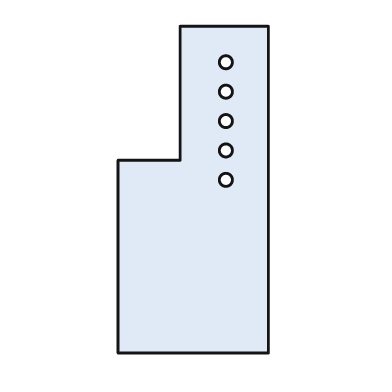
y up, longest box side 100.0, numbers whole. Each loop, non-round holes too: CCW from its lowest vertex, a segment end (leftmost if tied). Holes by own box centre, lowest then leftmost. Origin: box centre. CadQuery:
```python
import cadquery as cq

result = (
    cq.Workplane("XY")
    .moveTo(-23.0, -50.0)
    .lineTo(23.0, -50.0)
    .lineTo(23.0, 50.0)
    .lineTo(-4.0, 50.0)
    .lineTo(-4.0, 9.0)
    .lineTo(-23.0, 9.0)
    .close()
    .moveTo(10.0, 3.0)
    .circle(2.0)
    .moveTo(10.0, 12.0)
    .circle(2.0)
    .moveTo(10.0, 21.0)
    .circle(2.0)
    .moveTo(10.0, 30.0)
    .circle(2.0)
    .moveTo(10.0, 39.0)
    .circle(2.0)
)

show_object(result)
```